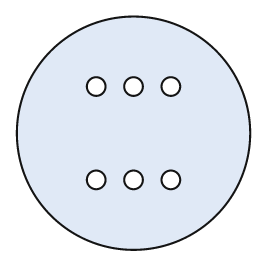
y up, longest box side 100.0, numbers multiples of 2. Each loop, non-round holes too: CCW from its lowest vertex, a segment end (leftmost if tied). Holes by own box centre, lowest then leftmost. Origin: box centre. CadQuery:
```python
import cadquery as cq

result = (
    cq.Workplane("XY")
    .moveTo(0.0, 0.0)
    .circle(50.0)
    .moveTo(-16.0, -20.0)
    .circle(4.0)
    .moveTo(0.0, -20.0)
    .circle(4.0)
    .moveTo(16.0, -20.0)
    .circle(4.0)
    .moveTo(-16.0, 20.0)
    .circle(4.0)
    .moveTo(0.0, 20.0)
    .circle(4.0)
    .moveTo(16.0, 20.0)
    .circle(4.0)
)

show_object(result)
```